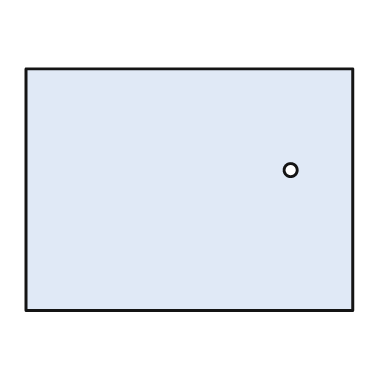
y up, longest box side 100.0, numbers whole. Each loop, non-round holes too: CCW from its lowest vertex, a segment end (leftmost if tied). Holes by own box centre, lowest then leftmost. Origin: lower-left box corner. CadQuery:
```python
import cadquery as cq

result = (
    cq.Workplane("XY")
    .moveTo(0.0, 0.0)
    .lineTo(100.0, 0.0)
    .lineTo(100.0, 74.0)
    .lineTo(0.0, 74.0)
    .close()
    .moveTo(81.0, 43.0)
    .circle(2.0)
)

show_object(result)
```